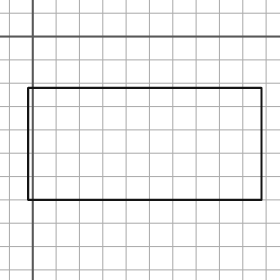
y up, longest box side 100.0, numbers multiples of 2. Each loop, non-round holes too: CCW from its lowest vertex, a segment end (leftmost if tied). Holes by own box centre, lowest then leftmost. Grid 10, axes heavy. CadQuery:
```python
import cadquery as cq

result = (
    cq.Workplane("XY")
    .moveTo(-2.0, -70.0)
    .lineTo(98.0, -70.0)
    .lineTo(98.0, -22.0)
    .lineTo(-2.0, -22.0)
    .close()
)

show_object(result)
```